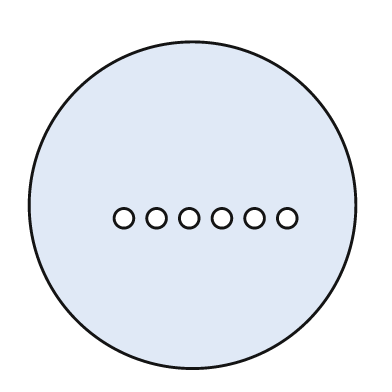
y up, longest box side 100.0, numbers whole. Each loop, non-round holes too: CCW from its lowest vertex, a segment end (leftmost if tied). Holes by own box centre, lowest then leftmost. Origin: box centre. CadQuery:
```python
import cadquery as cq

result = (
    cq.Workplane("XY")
    .moveTo(0.0, 0.0)
    .circle(50.0)
    .moveTo(-21.0, -4.0)
    .circle(3.0)
    .moveTo(-11.0, -4.0)
    .circle(3.0)
    .moveTo(-1.0, -4.0)
    .circle(3.0)
    .moveTo(9.0, -4.0)
    .circle(3.0)
    .moveTo(19.0, -4.0)
    .circle(3.0)
    .moveTo(29.0, -4.0)
    .circle(3.0)
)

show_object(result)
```